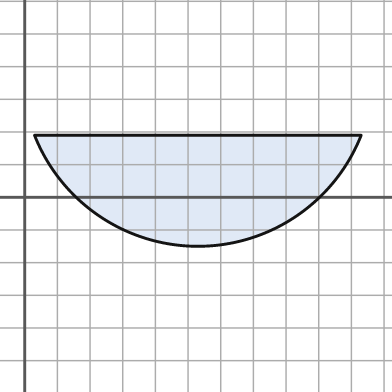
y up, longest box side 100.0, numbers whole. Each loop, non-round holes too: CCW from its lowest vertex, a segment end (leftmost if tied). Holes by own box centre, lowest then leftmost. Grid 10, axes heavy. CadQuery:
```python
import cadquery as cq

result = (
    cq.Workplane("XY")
    .moveTo(3.0, 19.0)
    .threePointArc((53.0, -15.0), (103.0, 19.0))
    .close()
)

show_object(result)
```